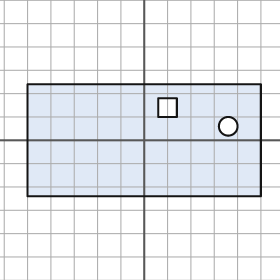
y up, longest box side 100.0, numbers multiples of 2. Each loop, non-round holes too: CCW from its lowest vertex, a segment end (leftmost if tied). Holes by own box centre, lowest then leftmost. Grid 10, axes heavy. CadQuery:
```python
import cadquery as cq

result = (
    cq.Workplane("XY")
    .moveTo(-50.0, -24.0)
    .lineTo(50.0, -24.0)
    .lineTo(50.0, 24.0)
    .lineTo(-50.0, 24.0)
    .close()
    .moveTo(36.0, 6.0)
    .circle(4.0)
    .moveTo(6.0, 10.0)
    .lineTo(14.0, 10.0)
    .lineTo(14.0, 18.0)
    .lineTo(6.0, 18.0)
    .close()
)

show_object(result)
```